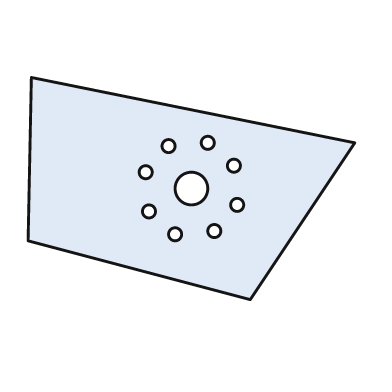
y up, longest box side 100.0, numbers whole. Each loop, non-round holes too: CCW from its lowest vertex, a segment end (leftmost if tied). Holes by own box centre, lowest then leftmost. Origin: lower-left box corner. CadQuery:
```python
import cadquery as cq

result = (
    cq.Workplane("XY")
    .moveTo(68.0, 0.0)
    .lineTo(100.0, 48.0)
    .lineTo(1.0, 68.0)
    .lineTo(0.0, 18.0)
    .close()
    .moveTo(45.0, 20.0)
    .circle(2.0)
    .moveTo(57.0, 21.0)
    .circle(2.0)
    .moveTo(37.0, 27.0)
    .circle(2.0)
    .moveTo(64.0, 29.0)
    .circle(2.0)
    .moveTo(50.0, 34.0)
    .circle(5.0)
    .moveTo(36.0, 39.0)
    .circle(2.0)
    .moveTo(63.0, 41.0)
    .circle(2.0)
    .moveTo(43.0, 47.0)
    .circle(2.0)
    .moveTo(55.0, 48.0)
    .circle(2.0)
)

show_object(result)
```